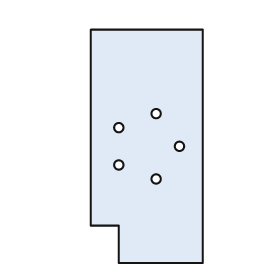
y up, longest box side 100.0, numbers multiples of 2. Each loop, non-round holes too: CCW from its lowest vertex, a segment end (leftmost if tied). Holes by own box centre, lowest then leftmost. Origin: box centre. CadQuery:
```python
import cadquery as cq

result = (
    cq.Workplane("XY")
    .moveTo(-12.0, -50.0)
    .lineTo(24.0, -50.0)
    .lineTo(24.0, 50.0)
    .lineTo(-24.0, 50.0)
    .lineTo(-24.0, -34.0)
    .lineTo(-12.0, -34.0)
    .close()
    .moveTo(4.0, -14.0)
    .circle(2.0)
    .moveTo(-12.0, -8.0)
    .circle(2.0)
    .moveTo(14.0, 0.0)
    .circle(2.0)
    .moveTo(-12.0, 8.0)
    .circle(2.0)
    .moveTo(4.0, 14.0)
    .circle(2.0)
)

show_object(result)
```